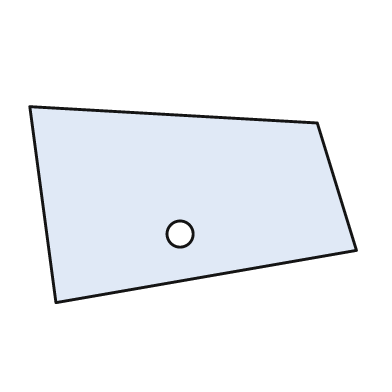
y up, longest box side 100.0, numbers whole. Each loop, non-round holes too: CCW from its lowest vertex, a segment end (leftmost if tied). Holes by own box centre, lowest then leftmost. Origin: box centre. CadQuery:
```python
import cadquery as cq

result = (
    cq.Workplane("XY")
    .moveTo(-42.0, -30.0)
    .lineTo(50.0, -14.0)
    .lineTo(38.0, 25.0)
    .lineTo(-50.0, 30.0)
    .close()
    .moveTo(-4.0, -9.0)
    .circle(4.0)
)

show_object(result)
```